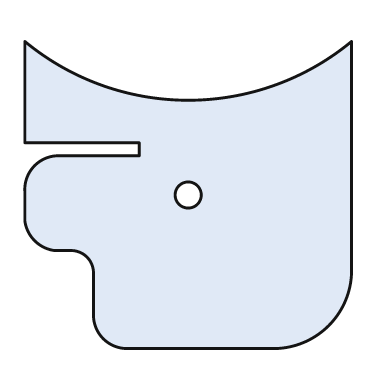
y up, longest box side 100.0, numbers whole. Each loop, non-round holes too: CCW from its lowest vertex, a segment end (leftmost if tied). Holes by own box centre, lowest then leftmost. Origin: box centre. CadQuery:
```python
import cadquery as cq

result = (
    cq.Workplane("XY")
    .moveTo(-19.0, -47.0)
    .lineTo(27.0, -47.0)
    .threePointArc((43.0, -40.0), (50.0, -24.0))
    .lineTo(50.0, 47.0)
    .threePointArc((0.0, 29.0), (-50.0, 47.0))
    .lineTo(-50.0, 16.0)
    .lineTo(-15.0, 16.0)
    .lineTo(-15.0, 12.0)
    .lineTo(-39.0, 12.0)
    .threePointArc((-47.0, 9.0), (-50.0, 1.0))
    .lineTo(-50.0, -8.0)
    .threePointArc((-47.0, -14.0), (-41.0, -17.0))
    .lineTo(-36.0, -17.0)
    .threePointArc((-31.0, -19.0), (-29.0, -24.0))
    .lineTo(-29.0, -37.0)
    .threePointArc((-26.0, -44.0), (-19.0, -47.0))
    .close()
    .moveTo(0.0, 0.0)
    .circle(4.0)
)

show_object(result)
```